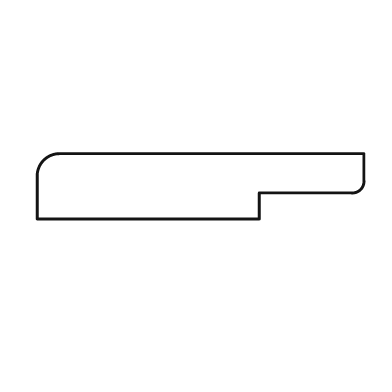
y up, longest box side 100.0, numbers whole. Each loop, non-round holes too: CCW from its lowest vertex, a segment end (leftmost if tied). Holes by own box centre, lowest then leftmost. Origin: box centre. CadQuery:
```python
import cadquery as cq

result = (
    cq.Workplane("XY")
    .moveTo(-50.0, -10.0)
    .lineTo(18.0, -10.0)
    .lineTo(18.0, -2.0)
    .lineTo(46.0, -2.0)
    .threePointArc((49.0, -1.0), (50.0, 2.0))
    .lineTo(50.0, 10.0)
    .lineTo(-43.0, 10.0)
    .threePointArc((-48.0, 8.0), (-50.0, 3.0))
    .close()
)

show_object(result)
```